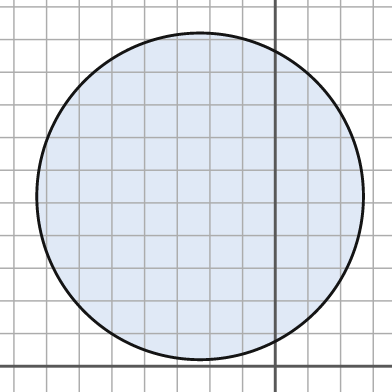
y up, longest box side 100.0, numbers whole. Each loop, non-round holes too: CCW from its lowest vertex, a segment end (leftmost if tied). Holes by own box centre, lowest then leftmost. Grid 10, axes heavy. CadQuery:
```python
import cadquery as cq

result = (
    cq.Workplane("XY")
    .moveTo(-23.0, 52.0)
    .circle(50.0)
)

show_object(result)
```